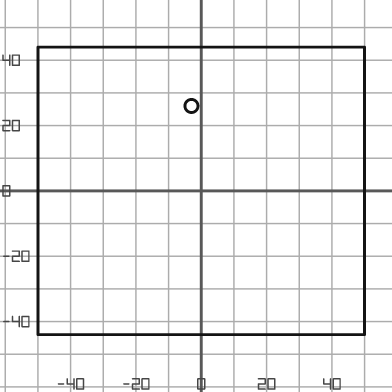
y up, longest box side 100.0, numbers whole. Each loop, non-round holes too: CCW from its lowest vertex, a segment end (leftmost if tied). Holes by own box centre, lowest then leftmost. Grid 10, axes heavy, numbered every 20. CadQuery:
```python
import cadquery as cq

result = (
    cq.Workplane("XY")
    .moveTo(-50.0, -44.0)
    .lineTo(50.0, -44.0)
    .lineTo(50.0, 44.0)
    .lineTo(-50.0, 44.0)
    .close()
    .moveTo(-3.0, 26.0)
    .circle(2.0)
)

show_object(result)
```